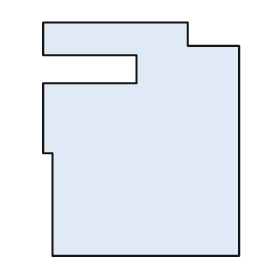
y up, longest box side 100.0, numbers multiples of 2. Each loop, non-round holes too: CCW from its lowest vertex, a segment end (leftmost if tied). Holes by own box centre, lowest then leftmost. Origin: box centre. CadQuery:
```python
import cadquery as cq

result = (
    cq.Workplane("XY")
    .moveTo(-38.0, -50.0)
    .lineTo(42.0, -50.0)
    .lineTo(42.0, 40.0)
    .lineTo(20.0, 40.0)
    .lineTo(20.0, 50.0)
    .lineTo(-42.0, 50.0)
    .lineTo(-42.0, 36.0)
    .lineTo(-2.0, 36.0)
    .lineTo(-2.0, 24.0)
    .lineTo(-42.0, 24.0)
    .lineTo(-42.0, -6.0)
    .lineTo(-38.0, -6.0)
    .close()
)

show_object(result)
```